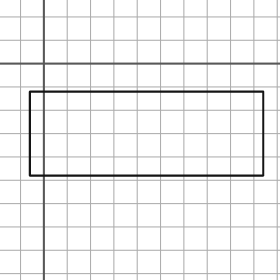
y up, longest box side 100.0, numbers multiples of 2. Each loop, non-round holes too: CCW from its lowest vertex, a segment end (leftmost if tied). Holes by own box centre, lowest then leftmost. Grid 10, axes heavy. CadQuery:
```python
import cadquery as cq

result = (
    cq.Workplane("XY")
    .moveTo(-6.0, -48.0)
    .lineTo(94.0, -48.0)
    .lineTo(94.0, -12.0)
    .lineTo(-6.0, -12.0)
    .close()
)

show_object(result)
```